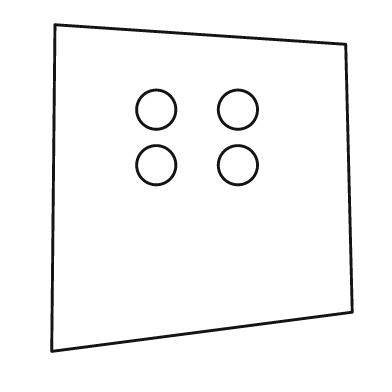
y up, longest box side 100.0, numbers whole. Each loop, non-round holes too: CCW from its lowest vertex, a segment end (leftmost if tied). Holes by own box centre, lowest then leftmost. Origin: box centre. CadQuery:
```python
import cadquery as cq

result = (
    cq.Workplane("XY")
    .moveTo(-46.0, -50.0)
    .lineTo(46.0, -38.0)
    .lineTo(44.0, 44.0)
    .lineTo(-45.0, 50.0)
    .close()
    .moveTo(-14.0, 7.0)
    .circle(6.0)
    .moveTo(11.0, 7.0)
    .circle(6.0)
    .moveTo(-14.0, 24.0)
    .circle(6.0)
    .moveTo(11.0, 24.0)
    .circle(6.0)
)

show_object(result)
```